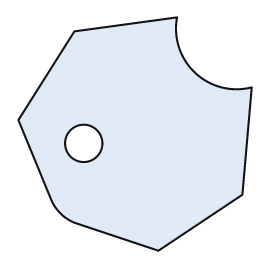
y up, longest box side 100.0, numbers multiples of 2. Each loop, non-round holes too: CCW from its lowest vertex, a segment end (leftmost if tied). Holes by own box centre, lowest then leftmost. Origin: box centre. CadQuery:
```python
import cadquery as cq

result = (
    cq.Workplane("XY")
    .moveTo(10.0, -50.0)
    .lineTo(46.0, -26.0)
    .lineTo(50.0, 20.0)
    .threePointArc((26.0, 26.0), (18.0, 50.0))
    .lineTo(-26.0, 44.0)
    .lineTo(-50.0, 6.0)
    .lineTo(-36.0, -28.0)
    .threePointArc((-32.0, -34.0), (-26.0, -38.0))
    .close()
    .moveTo(-22.0, -4.0)
    .circle(8.0)
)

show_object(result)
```